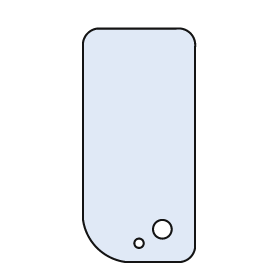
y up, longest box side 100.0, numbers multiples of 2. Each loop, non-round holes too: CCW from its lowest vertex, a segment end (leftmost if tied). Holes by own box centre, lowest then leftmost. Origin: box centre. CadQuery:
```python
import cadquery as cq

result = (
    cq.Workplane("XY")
    .moveTo(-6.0, -50.0)
    .lineTo(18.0, -50.0)
    .threePointArc((22.0, -48.0), (24.0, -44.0))
    .lineTo(24.0, 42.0)
    .threePointArc((22.0, 48.0), (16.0, 50.0))
    .lineTo(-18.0, 50.0)
    .threePointArc((-22.0, 48.0), (-24.0, 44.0))
    .lineTo(-24.0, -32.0)
    .threePointArc((-18.0, -44.0), (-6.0, -50.0))
    .close()
    .moveTo(0.0, -42.0)
    .circle(2.0)
    .moveTo(10.0, -36.0)
    .circle(4.0)
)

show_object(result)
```